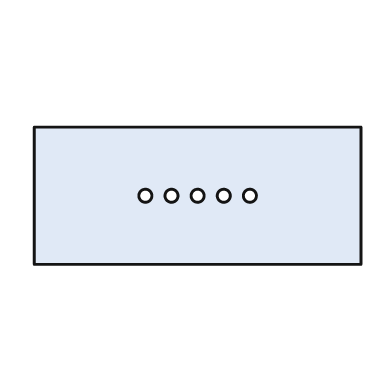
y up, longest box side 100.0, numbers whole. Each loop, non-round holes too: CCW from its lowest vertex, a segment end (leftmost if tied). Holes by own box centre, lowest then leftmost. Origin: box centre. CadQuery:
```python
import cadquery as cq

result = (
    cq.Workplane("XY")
    .moveTo(-50.0, -21.0)
    .lineTo(50.0, -21.0)
    .lineTo(50.0, 21.0)
    .lineTo(-50.0, 21.0)
    .close()
    .moveTo(-16.0, 0.0)
    .circle(2.0)
    .moveTo(-8.0, 0.0)
    .circle(2.0)
    .moveTo(0.0, 0.0)
    .circle(2.0)
    .moveTo(8.0, 0.0)
    .circle(2.0)
    .moveTo(16.0, 0.0)
    .circle(2.0)
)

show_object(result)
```